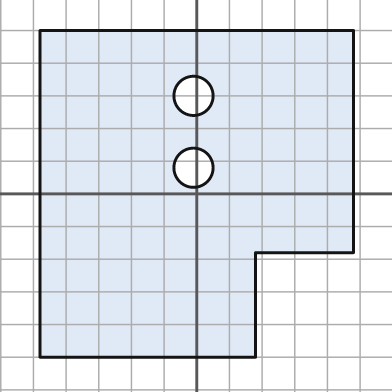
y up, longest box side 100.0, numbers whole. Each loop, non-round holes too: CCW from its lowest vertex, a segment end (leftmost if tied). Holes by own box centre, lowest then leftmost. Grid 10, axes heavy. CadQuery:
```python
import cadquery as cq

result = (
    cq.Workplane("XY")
    .moveTo(-48.0, -50.0)
    .lineTo(18.0, -50.0)
    .lineTo(18.0, -18.0)
    .lineTo(48.0, -18.0)
    .lineTo(48.0, 50.0)
    .lineTo(-48.0, 50.0)
    .close()
    .moveTo(-1.0, 8.0)
    .circle(6.0)
    .moveTo(-1.0, 30.0)
    .circle(6.0)
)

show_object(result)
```